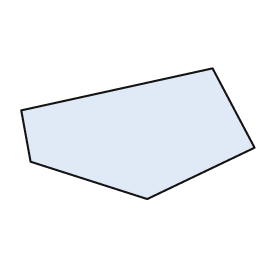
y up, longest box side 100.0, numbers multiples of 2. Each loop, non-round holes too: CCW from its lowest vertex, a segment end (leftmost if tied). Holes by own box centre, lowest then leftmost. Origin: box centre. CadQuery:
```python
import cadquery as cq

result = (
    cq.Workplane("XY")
    .moveTo(4.0, -28.0)
    .lineTo(50.0, -6.0)
    .lineTo(32.0, 28.0)
    .lineTo(-50.0, 10.0)
    .lineTo(-46.0, -12.0)
    .close()
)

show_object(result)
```